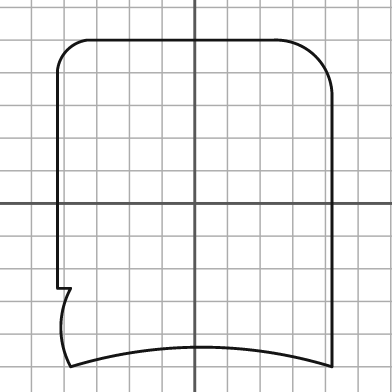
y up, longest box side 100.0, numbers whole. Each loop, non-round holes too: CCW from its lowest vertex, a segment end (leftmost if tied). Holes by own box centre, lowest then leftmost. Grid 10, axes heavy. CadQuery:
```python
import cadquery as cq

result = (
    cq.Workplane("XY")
    .moveTo(-38.0, -50.0)
    .threePointArc((2.0, -44.0), (42.0, -50.0))
    .lineTo(42.0, 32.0)
    .threePointArc((37.0, 45.0), (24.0, 50.0))
    .lineTo(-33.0, 50.0)
    .threePointArc((-39.0, 47.0), (-42.0, 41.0))
    .lineTo(-42.0, -26.0)
    .lineTo(-38.0, -26.0)
    .threePointArc((-41.0, -38.0), (-38.0, -50.0))
    .close()
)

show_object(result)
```